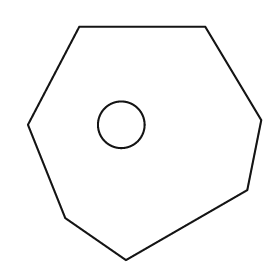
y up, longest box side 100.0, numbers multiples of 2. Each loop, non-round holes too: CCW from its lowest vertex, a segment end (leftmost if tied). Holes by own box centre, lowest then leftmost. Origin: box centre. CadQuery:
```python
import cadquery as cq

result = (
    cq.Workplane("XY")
    .moveTo(-8.0, -50.0)
    .lineTo(44.0, -20.0)
    .lineTo(50.0, 10.0)
    .lineTo(26.0, 50.0)
    .lineTo(-28.0, 50.0)
    .lineTo(-50.0, 8.0)
    .lineTo(-34.0, -32.0)
    .close()
    .moveTo(-10.0, 8.0)
    .circle(10.0)
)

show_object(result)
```